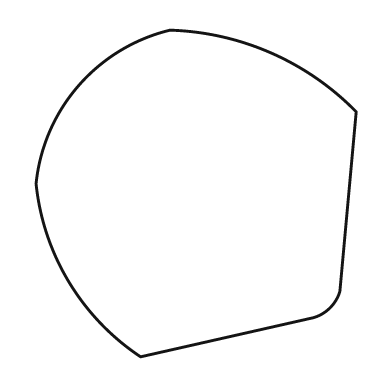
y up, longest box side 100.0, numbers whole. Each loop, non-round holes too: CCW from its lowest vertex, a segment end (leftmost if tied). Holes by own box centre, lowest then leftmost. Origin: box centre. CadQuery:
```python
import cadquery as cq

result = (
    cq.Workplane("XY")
    .moveTo(-17.0, -50.0)
    .lineTo(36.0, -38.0)
    .threePointArc((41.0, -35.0), (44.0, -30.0))
    .lineTo(49.0, 25.0)
    .threePointArc((23.0, 43.0), (-8.0, 50.0))
    .threePointArc((-36.0, 33.0), (-49.0, 3.0))
    .threePointArc((-39.0, -27.0), (-17.0, -50.0))
    .close()
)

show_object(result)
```